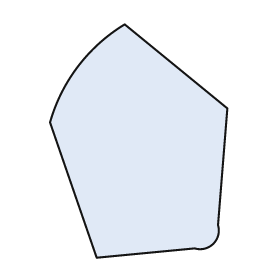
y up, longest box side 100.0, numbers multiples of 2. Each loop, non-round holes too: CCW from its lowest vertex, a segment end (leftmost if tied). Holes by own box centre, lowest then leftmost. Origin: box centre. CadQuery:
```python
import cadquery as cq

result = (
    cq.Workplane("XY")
    .moveTo(-18.0, -50.0)
    .lineTo(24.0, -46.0)
    .threePointArc((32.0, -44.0), (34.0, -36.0))
    .lineTo(38.0, 14.0)
    .lineTo(-6.0, 50.0)
    .threePointArc((-26.0, 32.0), (-38.0, 8.0))
    .close()
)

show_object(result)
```